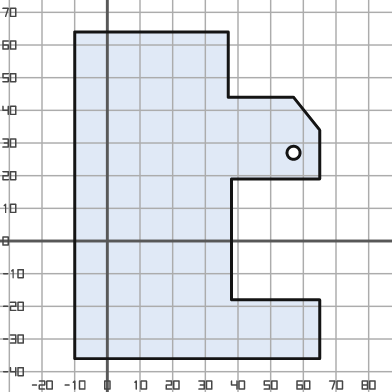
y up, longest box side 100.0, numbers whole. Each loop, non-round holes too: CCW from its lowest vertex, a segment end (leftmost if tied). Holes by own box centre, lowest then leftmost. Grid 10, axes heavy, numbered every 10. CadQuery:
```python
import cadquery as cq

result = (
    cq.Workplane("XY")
    .moveTo(-10.0, -36.0)
    .lineTo(65.0, -36.0)
    .lineTo(65.0, -18.0)
    .lineTo(38.0, -18.0)
    .lineTo(38.0, 19.0)
    .lineTo(65.0, 19.0)
    .lineTo(65.0, 34.0)
    .lineTo(57.0, 44.0)
    .lineTo(37.0, 44.0)
    .lineTo(37.0, 64.0)
    .lineTo(-10.0, 64.0)
    .close()
    .moveTo(57.0, 27.0)
    .circle(2.0)
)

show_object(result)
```